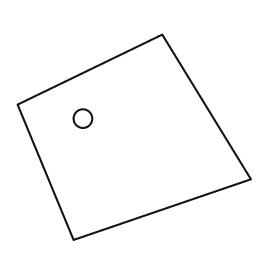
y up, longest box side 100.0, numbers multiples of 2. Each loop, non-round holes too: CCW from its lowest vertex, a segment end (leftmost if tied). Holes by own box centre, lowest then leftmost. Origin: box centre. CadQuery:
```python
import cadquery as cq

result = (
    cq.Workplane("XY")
    .moveTo(-26.0, -44.0)
    .lineTo(50.0, -18.0)
    .lineTo(12.0, 44.0)
    .lineTo(-50.0, 14.0)
    .close()
    .moveTo(-22.0, 8.0)
    .circle(4.0)
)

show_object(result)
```